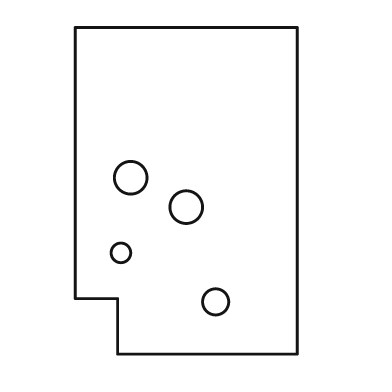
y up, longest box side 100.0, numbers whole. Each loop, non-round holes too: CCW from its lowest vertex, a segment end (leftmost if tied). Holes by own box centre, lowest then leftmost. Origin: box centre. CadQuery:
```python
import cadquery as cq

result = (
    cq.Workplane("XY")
    .moveTo(-21.0, -50.0)
    .lineTo(34.0, -50.0)
    .lineTo(34.0, 50.0)
    .lineTo(-34.0, 50.0)
    .lineTo(-34.0, -33.0)
    .lineTo(-21.0, -33.0)
    .close()
    .moveTo(9.0, -34.0)
    .circle(4.0)
    .moveTo(-20.0, -19.0)
    .circle(3.0)
    .moveTo(0.0, -5.0)
    .circle(5.0)
    .moveTo(-17.0, 4.0)
    .circle(5.0)
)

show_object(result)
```